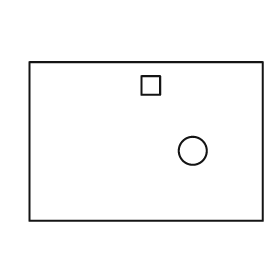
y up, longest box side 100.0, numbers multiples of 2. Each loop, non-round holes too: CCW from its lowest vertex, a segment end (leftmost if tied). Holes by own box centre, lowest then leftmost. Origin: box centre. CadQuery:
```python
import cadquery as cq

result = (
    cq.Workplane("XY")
    .moveTo(-50.0, -34.0)
    .lineTo(50.0, -34.0)
    .lineTo(50.0, 34.0)
    .lineTo(-50.0, 34.0)
    .close()
    .moveTo(20.0, -4.0)
    .circle(6.0)
    .moveTo(-2.0, 20.0)
    .lineTo(6.0, 20.0)
    .lineTo(6.0, 28.0)
    .lineTo(-2.0, 28.0)
    .close()
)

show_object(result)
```